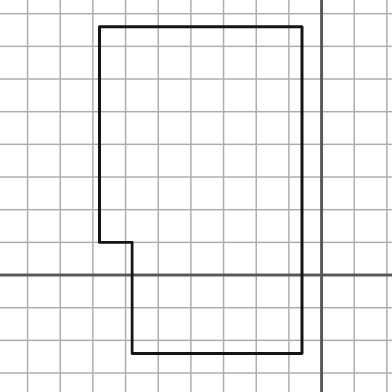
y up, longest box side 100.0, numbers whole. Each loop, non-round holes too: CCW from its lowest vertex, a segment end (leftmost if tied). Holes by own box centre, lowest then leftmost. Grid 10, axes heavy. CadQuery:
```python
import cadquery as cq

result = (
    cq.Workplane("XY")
    .moveTo(-58.0, -24.0)
    .lineTo(-6.0, -24.0)
    .lineTo(-6.0, 76.0)
    .lineTo(-68.0, 76.0)
    .lineTo(-68.0, 10.0)
    .lineTo(-58.0, 10.0)
    .close()
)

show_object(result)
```